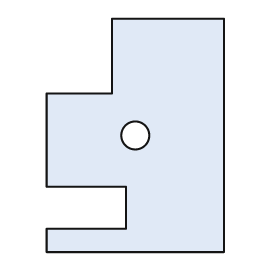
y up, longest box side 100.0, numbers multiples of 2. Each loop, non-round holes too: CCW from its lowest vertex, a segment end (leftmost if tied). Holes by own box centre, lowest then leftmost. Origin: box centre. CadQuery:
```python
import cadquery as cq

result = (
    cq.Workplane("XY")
    .moveTo(-38.0, -50.0)
    .lineTo(38.0, -50.0)
    .lineTo(38.0, 50.0)
    .lineTo(-10.0, 50.0)
    .lineTo(-10.0, 18.0)
    .lineTo(-38.0, 18.0)
    .lineTo(-38.0, -22.0)
    .lineTo(-4.0, -22.0)
    .lineTo(-4.0, -40.0)
    .lineTo(-38.0, -40.0)
    .close()
    .moveTo(0.0, 0.0)
    .circle(6.0)
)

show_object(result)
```